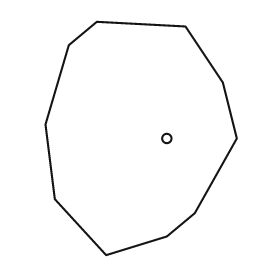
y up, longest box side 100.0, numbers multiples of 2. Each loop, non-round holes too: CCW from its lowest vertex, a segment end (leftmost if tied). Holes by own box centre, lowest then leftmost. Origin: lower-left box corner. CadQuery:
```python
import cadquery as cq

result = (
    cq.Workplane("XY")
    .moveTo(26.0, 0.0)
    .lineTo(52.0, 8.0)
    .lineTo(64.0, 18.0)
    .lineTo(82.0, 50.0)
    .lineTo(76.0, 74.0)
    .lineTo(60.0, 98.0)
    .lineTo(22.0, 100.0)
    .lineTo(10.0, 90.0)
    .lineTo(0.0, 56.0)
    .lineTo(4.0, 24.0)
    .close()
    .moveTo(52.0, 50.0)
    .circle(2.0)
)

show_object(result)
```